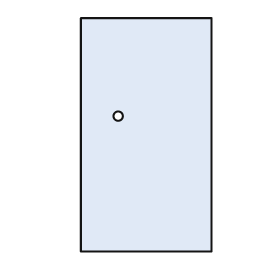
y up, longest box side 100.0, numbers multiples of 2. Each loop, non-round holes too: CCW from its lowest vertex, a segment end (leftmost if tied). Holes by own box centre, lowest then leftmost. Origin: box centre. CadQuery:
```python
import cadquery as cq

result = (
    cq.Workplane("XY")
    .moveTo(-28.0, -50.0)
    .lineTo(28.0, -50.0)
    .lineTo(28.0, 50.0)
    .lineTo(-28.0, 50.0)
    .close()
    .moveTo(-12.0, 8.0)
    .circle(2.0)
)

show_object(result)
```